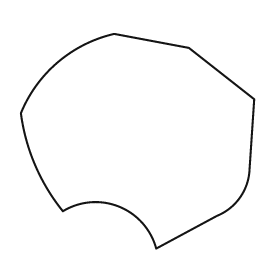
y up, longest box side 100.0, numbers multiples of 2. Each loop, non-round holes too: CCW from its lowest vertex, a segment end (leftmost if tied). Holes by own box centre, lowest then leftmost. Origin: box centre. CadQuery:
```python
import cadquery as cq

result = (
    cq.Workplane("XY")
    .moveTo(8.0, -46.0)
    .lineTo(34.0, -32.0)
    .threePointArc((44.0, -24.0), (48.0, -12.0))
    .lineTo(50.0, 18.0)
    .lineTo(22.0, 40.0)
    .lineTo(-10.0, 46.0)
    .threePointArc((-34.0, 34.0), (-50.0, 12.0))
    .threePointArc((-44.0, -10.0), (-32.0, -30.0))
    .threePointArc((-8.0, -28.0), (8.0, -46.0))
    .close()
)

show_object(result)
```